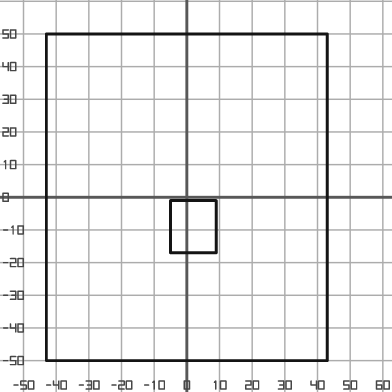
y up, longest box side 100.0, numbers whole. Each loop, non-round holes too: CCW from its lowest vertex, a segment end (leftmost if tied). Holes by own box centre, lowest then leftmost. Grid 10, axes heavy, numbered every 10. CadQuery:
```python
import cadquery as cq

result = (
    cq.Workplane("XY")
    .moveTo(-43.0, -50.0)
    .lineTo(43.0, -50.0)
    .lineTo(43.0, 50.0)
    .lineTo(-43.0, 50.0)
    .close()
    .moveTo(-5.0, -17.0)
    .lineTo(9.0, -17.0)
    .lineTo(9.0, -1.0)
    .lineTo(-5.0, -1.0)
    .close()
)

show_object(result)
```